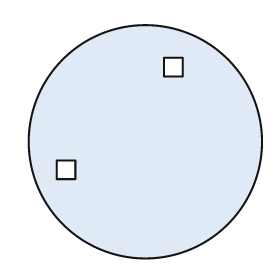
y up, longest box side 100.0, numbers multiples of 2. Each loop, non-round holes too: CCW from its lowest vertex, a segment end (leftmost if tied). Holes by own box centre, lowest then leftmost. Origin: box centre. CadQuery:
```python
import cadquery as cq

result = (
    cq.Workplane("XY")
    .moveTo(0.0, 0.0)
    .circle(50.0)
    .moveTo(-38.0, -16.0)
    .lineTo(-30.0, -16.0)
    .lineTo(-30.0, -8.0)
    .lineTo(-38.0, -8.0)
    .close()
    .moveTo(8.0, 28.0)
    .lineTo(16.0, 28.0)
    .lineTo(16.0, 36.0)
    .lineTo(8.0, 36.0)
    .close()
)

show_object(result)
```